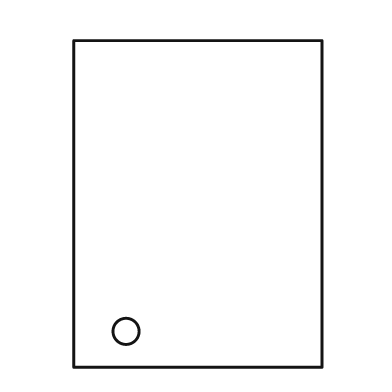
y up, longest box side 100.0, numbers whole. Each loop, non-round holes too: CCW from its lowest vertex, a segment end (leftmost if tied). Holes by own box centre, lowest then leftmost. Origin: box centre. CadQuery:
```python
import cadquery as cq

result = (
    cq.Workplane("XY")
    .moveTo(-38.0, -50.0)
    .lineTo(38.0, -50.0)
    .lineTo(38.0, 50.0)
    .lineTo(-38.0, 50.0)
    .close()
    .moveTo(-22.0, -39.0)
    .circle(4.0)
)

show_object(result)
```